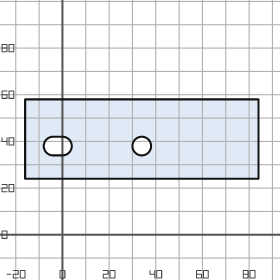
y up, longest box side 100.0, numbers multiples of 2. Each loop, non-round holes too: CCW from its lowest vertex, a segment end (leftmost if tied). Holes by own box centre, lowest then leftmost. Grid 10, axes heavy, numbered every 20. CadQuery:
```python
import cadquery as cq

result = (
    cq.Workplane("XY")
    .moveTo(-16.0, 24.0)
    .lineTo(84.0, 24.0)
    .lineTo(84.0, 58.0)
    .lineTo(-16.0, 58.0)
    .close()
    .moveTo(-4.0, 34.0)
    .lineTo(0.0, 34.0)
    .threePointArc((4.0, 38.0), (0.0, 42.0))
    .lineTo(-4.0, 42.0)
    .threePointArc((-8.0, 38.0), (-4.0, 34.0))
    .close()
    .moveTo(34.0, 38.0)
    .circle(4.0)
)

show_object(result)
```